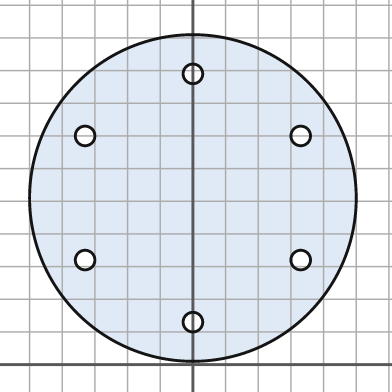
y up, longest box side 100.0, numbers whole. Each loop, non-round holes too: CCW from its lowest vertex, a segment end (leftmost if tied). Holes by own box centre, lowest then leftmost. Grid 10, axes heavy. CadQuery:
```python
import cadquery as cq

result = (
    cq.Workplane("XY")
    .moveTo(0.0, 51.0)
    .circle(50.0)
    .moveTo(0.0, 13.0)
    .circle(3.0)
    .moveTo(-33.0, 32.0)
    .circle(3.0)
    .moveTo(33.0, 32.0)
    .circle(3.0)
    .moveTo(-33.0, 70.0)
    .circle(3.0)
    .moveTo(33.0, 70.0)
    .circle(3.0)
    .moveTo(0.0, 89.0)
    .circle(3.0)
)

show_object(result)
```